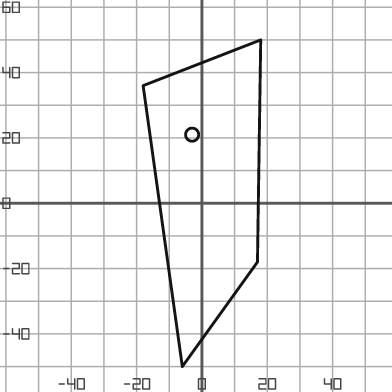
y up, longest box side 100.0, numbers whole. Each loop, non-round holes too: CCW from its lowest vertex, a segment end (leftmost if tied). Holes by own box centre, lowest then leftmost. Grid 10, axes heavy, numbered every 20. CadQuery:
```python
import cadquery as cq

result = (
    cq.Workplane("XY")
    .moveTo(-6.0, -50.0)
    .lineTo(17.0, -18.0)
    .lineTo(18.0, 50.0)
    .lineTo(-18.0, 36.0)
    .close()
    .moveTo(-3.0, 21.0)
    .circle(2.0)
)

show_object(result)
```